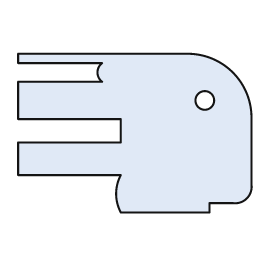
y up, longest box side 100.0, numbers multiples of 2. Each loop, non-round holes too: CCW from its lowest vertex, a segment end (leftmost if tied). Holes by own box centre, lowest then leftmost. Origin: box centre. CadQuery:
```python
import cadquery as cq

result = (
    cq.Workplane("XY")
    .moveTo(-6.0, -34.0)
    .lineTo(32.0, -34.0)
    .lineTo(32.0, -30.0)
    .lineTo(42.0, -30.0)
    .threePointArc((48.0, -28.0), (50.0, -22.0))
    .lineTo(50.0, 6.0)
    .threePointArc((42.0, 26.0), (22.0, 34.0))
    .lineTo(-50.0, 34.0)
    .lineTo(-50.0, 30.0)
    .lineTo(-14.0, 30.0)
    .threePointArc((-16.0, 26.0), (-14.0, 22.0))
    .lineTo(-50.0, 22.0)
    .lineTo(-50.0, 6.0)
    .lineTo(-6.0, 6.0)
    .lineTo(-6.0, -4.0)
    .lineTo(-50.0, -4.0)
    .lineTo(-50.0, -18.0)
    .lineTo(-6.0, -18.0)
    .threePointArc((-8.0, -26.0), (-6.0, -34.0))
    .close()
    .moveTo(30.0, 14.0)
    .circle(4.0)
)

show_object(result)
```